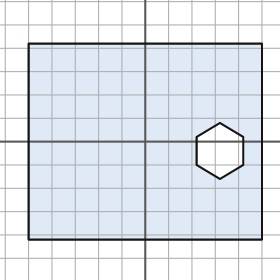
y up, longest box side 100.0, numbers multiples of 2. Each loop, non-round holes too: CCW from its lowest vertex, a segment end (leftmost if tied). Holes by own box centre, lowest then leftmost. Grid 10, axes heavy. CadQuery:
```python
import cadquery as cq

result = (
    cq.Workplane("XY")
    .moveTo(-50.0, -42.0)
    .lineTo(50.0, -42.0)
    .lineTo(50.0, 42.0)
    .lineTo(-50.0, 42.0)
    .close()
    .moveTo(32.0, -16.0)
    .lineTo(42.0, -10.0)
    .lineTo(42.0, 2.0)
    .lineTo(32.0, 8.0)
    .lineTo(22.0, 2.0)
    .lineTo(22.0, -10.0)
    .close()
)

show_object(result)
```